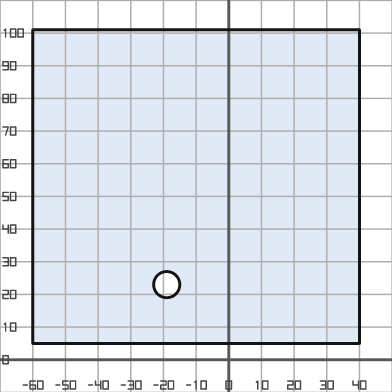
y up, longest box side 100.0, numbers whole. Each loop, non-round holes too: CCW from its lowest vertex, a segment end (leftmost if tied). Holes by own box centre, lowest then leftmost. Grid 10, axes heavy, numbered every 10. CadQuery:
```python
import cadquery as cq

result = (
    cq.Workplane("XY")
    .moveTo(-60.0, 5.0)
    .lineTo(40.0, 5.0)
    .lineTo(40.0, 101.0)
    .lineTo(-60.0, 101.0)
    .close()
    .moveTo(-19.0, 23.0)
    .circle(4.0)
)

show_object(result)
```